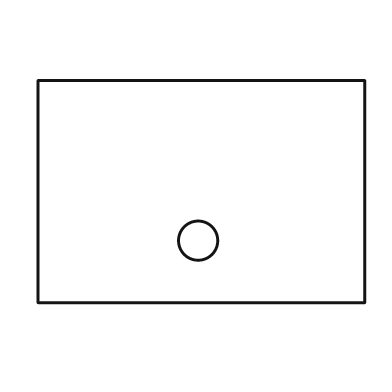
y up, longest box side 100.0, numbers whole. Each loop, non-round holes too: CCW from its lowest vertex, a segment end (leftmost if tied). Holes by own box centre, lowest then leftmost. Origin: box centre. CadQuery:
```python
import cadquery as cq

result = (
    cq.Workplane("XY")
    .moveTo(-50.0, -34.0)
    .lineTo(50.0, -34.0)
    .lineTo(50.0, 34.0)
    .lineTo(-50.0, 34.0)
    .close()
    .moveTo(-1.0, -15.0)
    .circle(6.0)
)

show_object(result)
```